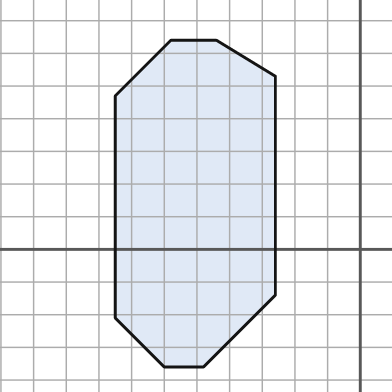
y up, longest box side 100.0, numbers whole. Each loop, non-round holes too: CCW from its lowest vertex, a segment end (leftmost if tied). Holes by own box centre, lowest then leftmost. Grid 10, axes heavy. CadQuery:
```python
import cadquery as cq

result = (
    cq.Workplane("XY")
    .moveTo(-60.0, -36.0)
    .lineTo(-48.0, -36.0)
    .lineTo(-26.0, -14.0)
    .lineTo(-26.0, 53.0)
    .lineTo(-44.0, 64.0)
    .lineTo(-58.0, 64.0)
    .lineTo(-75.0, 47.0)
    .lineTo(-75.0, -21.0)
    .close()
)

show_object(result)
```